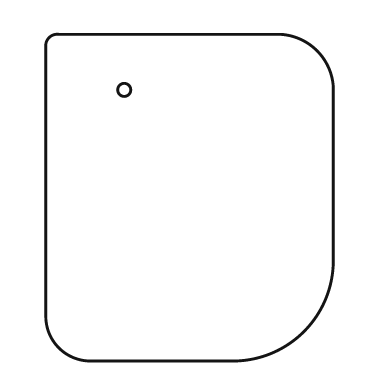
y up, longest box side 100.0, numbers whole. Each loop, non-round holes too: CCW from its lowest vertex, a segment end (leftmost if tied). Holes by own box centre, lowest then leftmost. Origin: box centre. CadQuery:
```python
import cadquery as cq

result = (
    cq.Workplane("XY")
    .moveTo(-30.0, -50.0)
    .lineTo(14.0, -50.0)
    .threePointArc((35.0, -41.0), (44.0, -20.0))
    .lineTo(44.0, 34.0)
    .threePointArc((39.0, 45.0), (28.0, 50.0))
    .lineTo(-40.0, 50.0)
    .threePointArc((-43.0, 49.0), (-44.0, 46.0))
    .lineTo(-44.0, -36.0)
    .threePointArc((-40.0, -46.0), (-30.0, -50.0))
    .close()
    .moveTo(-20.0, 33.0)
    .circle(2.0)
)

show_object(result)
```